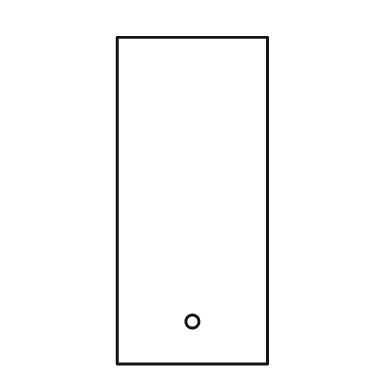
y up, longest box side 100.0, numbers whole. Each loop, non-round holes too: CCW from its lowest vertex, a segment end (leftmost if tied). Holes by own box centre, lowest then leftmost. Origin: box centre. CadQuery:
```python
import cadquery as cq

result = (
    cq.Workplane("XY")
    .moveTo(-23.0, -50.0)
    .lineTo(23.0, -50.0)
    .lineTo(23.0, 50.0)
    .lineTo(-23.0, 50.0)
    .close()
    .moveTo(0.0, -37.0)
    .circle(2.0)
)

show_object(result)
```